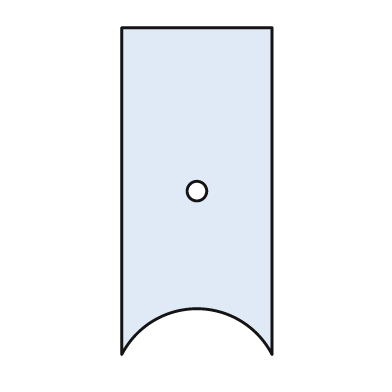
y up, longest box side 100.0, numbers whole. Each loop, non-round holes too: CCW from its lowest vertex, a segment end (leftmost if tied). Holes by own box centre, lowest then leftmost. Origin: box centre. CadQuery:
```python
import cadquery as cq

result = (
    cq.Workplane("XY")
    .moveTo(-23.0, -50.0)
    .threePointArc((0.0, -36.0), (23.0, -50.0))
    .lineTo(23.0, 50.0)
    .lineTo(-23.0, 50.0)
    .close()
    .moveTo(0.0, 0.0)
    .circle(3.0)
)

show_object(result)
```